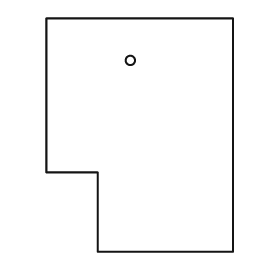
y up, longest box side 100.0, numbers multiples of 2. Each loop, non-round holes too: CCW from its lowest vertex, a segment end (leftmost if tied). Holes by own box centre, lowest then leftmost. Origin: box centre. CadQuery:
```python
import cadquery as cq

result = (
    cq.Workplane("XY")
    .moveTo(-18.0, -50.0)
    .lineTo(40.0, -50.0)
    .lineTo(40.0, 50.0)
    .lineTo(-40.0, 50.0)
    .lineTo(-40.0, -16.0)
    .lineTo(-18.0, -16.0)
    .close()
    .moveTo(-4.0, 32.0)
    .circle(2.0)
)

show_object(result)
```